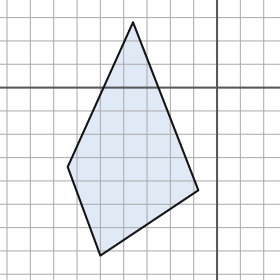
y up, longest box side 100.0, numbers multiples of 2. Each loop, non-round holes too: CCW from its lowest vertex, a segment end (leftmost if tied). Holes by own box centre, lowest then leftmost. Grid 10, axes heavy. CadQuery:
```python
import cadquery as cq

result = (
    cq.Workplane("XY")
    .moveTo(-50.0, -72.0)
    .lineTo(-8.0, -44.0)
    .lineTo(-36.0, 28.0)
    .lineTo(-64.0, -34.0)
    .close()
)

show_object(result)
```